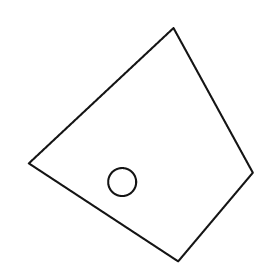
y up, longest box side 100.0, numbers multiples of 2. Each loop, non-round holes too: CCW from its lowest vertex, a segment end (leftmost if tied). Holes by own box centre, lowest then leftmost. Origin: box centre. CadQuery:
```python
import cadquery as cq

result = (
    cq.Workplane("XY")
    .moveTo(16.0, -50.0)
    .lineTo(48.0, -12.0)
    .lineTo(14.0, 50.0)
    .lineTo(-48.0, -8.0)
    .close()
    .moveTo(-8.0, -16.0)
    .circle(6.0)
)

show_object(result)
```